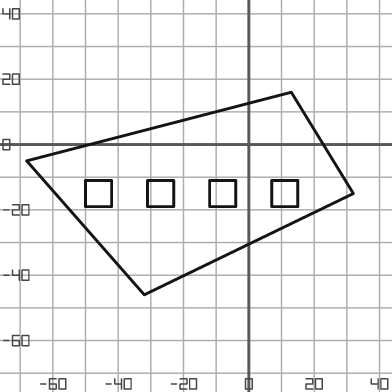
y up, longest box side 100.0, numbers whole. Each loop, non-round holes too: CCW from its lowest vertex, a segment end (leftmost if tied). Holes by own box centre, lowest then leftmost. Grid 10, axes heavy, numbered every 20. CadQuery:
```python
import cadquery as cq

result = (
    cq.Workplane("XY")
    .moveTo(-32.0, -46.0)
    .lineTo(32.0, -15.0)
    .lineTo(13.0, 16.0)
    .lineTo(-68.0, -5.0)
    .close()
    .moveTo(-50.0, -19.0)
    .lineTo(-42.0, -19.0)
    .lineTo(-42.0, -11.0)
    .lineTo(-50.0, -11.0)
    .close()
    .moveTo(-31.0, -19.0)
    .lineTo(-23.0, -19.0)
    .lineTo(-23.0, -11.0)
    .lineTo(-31.0, -11.0)
    .close()
    .moveTo(-12.0, -19.0)
    .lineTo(-4.0, -19.0)
    .lineTo(-4.0, -11.0)
    .lineTo(-12.0, -11.0)
    .close()
    .moveTo(7.0, -19.0)
    .lineTo(15.0, -19.0)
    .lineTo(15.0, -11.0)
    .lineTo(7.0, -11.0)
    .close()
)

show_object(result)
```